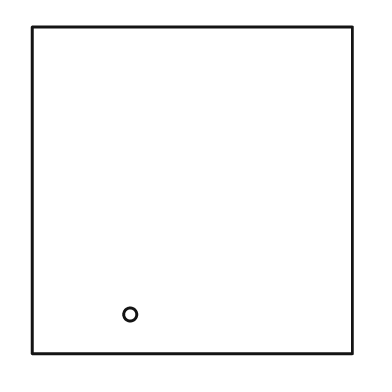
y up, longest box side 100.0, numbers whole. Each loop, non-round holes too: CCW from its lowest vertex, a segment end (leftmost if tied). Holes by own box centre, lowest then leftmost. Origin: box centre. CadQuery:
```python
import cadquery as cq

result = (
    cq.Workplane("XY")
    .moveTo(-49.0, -50.0)
    .lineTo(49.0, -50.0)
    .lineTo(49.0, 50.0)
    .lineTo(-49.0, 50.0)
    .close()
    .moveTo(-19.0, -38.0)
    .circle(2.0)
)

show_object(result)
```